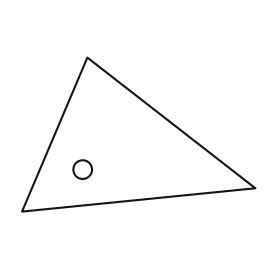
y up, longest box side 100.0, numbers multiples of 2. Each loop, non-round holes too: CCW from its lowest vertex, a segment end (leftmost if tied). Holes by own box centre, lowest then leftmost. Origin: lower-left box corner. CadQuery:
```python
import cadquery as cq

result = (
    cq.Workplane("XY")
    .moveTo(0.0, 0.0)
    .lineTo(100.0, 10.0)
    .lineTo(28.0, 66.0)
    .close()
    .moveTo(26.0, 18.0)
    .circle(4.0)
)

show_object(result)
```